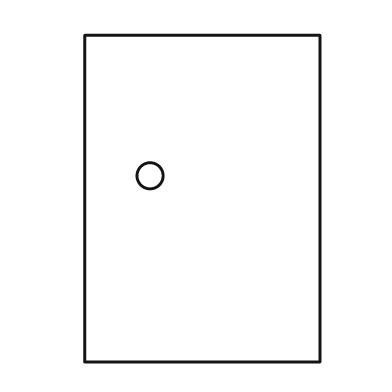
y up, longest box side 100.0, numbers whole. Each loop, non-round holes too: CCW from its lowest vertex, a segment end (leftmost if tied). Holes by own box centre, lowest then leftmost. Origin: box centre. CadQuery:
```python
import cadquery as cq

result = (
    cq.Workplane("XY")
    .moveTo(-36.0, -50.0)
    .lineTo(36.0, -50.0)
    .lineTo(36.0, 50.0)
    .lineTo(-36.0, 50.0)
    .close()
    .moveTo(-16.0, 7.0)
    .circle(4.0)
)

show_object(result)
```